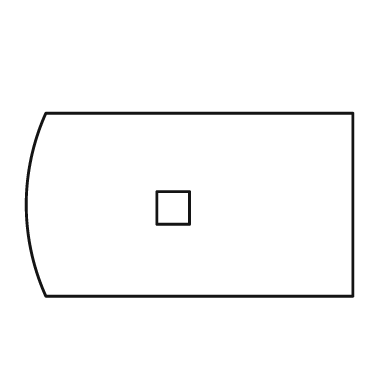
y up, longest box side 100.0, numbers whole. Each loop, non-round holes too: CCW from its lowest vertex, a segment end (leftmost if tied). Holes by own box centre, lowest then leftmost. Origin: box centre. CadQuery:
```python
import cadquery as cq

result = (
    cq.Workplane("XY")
    .moveTo(-44.0, -28.0)
    .lineTo(50.0, -28.0)
    .lineTo(50.0, 28.0)
    .lineTo(-44.0, 28.0)
    .threePointArc((-50.0, 0.0), (-44.0, -28.0))
    .close()
    .moveTo(-10.0, -6.0)
    .lineTo(0.0, -6.0)
    .lineTo(0.0, 4.0)
    .lineTo(-10.0, 4.0)
    .close()
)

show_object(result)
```